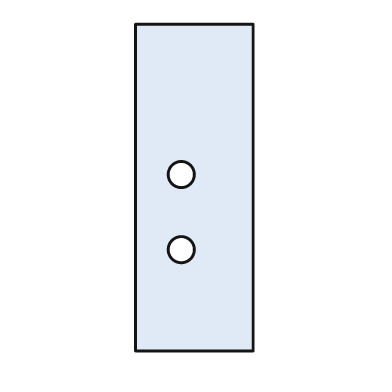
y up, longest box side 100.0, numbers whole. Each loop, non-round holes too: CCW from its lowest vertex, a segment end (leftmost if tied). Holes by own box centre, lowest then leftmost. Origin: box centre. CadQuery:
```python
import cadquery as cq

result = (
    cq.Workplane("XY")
    .moveTo(-18.0, -50.0)
    .lineTo(18.0, -50.0)
    .lineTo(18.0, 50.0)
    .lineTo(-18.0, 50.0)
    .close()
    .moveTo(-4.0, -19.0)
    .circle(4.0)
    .moveTo(-4.0, 4.0)
    .circle(4.0)
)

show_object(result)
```